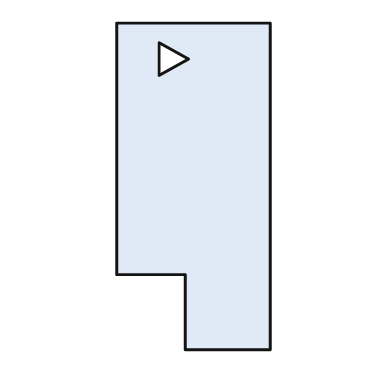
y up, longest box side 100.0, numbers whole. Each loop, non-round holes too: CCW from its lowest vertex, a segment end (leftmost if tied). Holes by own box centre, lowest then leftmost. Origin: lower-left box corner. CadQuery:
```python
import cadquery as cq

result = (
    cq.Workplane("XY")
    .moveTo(21.0, 0.0)
    .lineTo(47.0, 0.0)
    .lineTo(47.0, 100.0)
    .lineTo(0.0, 100.0)
    .lineTo(0.0, 23.0)
    .lineTo(21.0, 23.0)
    .close()
    .moveTo(13.0, 84.0)
    .lineTo(22.0, 89.0)
    .lineTo(13.0, 94.0)
    .close()
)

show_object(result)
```